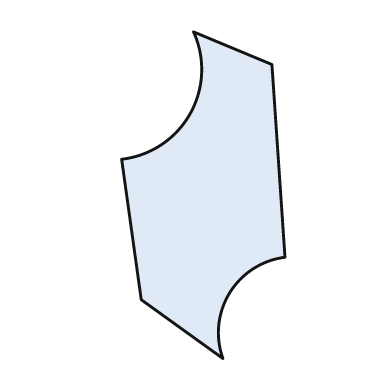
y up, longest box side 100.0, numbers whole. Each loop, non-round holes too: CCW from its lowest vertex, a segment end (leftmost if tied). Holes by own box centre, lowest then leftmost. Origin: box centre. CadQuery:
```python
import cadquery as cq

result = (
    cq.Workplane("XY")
    .moveTo(6.0, -50.0)
    .threePointArc((8.0, -30.0), (25.0, -19.0))
    .lineTo(21.0, 40.0)
    .lineTo(-3.0, 50.0)
    .threePointArc((-4.0, 25.0), (-25.0, 11.0))
    .lineTo(-19.0, -32.0)
    .close()
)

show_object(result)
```